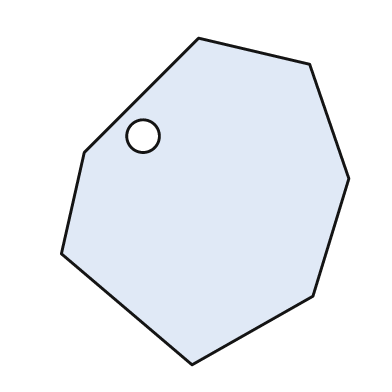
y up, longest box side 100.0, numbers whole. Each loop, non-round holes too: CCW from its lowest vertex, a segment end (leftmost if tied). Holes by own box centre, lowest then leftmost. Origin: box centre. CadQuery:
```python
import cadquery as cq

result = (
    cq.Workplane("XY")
    .moveTo(-4.0, -50.0)
    .lineTo(33.0, -29.0)
    .lineTo(44.0, 7.0)
    .lineTo(32.0, 42.0)
    .lineTo(-2.0, 50.0)
    .lineTo(-37.0, 15.0)
    .lineTo(-44.0, -16.0)
    .close()
    .moveTo(-19.0, 20.0)
    .circle(5.0)
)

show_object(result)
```